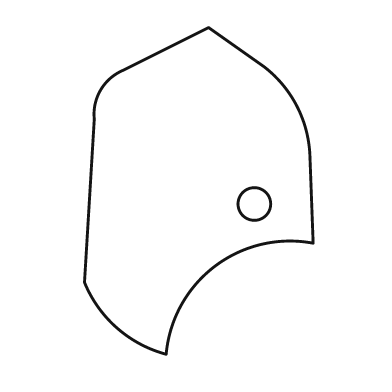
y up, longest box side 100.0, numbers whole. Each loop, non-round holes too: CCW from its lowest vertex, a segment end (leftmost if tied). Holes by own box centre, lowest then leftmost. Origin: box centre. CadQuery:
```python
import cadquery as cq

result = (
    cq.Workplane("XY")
    .moveTo(-10.0, -50.0)
    .threePointArc((5.0, -23.0), (35.0, -16.0))
    .lineTo(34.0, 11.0)
    .threePointArc((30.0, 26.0), (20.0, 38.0))
    .lineTo(3.0, 50.0)
    .lineTo(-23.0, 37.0)
    .threePointArc((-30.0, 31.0), (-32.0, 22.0))
    .lineTo(-35.0, -28.0)
    .threePointArc((-25.0, -42.0), (-10.0, -50.0))
    .close()
    .moveTo(17.0, -4.0)
    .circle(5.0)
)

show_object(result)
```